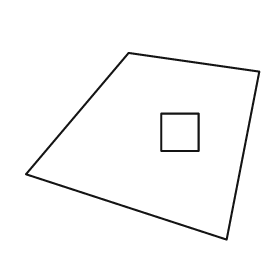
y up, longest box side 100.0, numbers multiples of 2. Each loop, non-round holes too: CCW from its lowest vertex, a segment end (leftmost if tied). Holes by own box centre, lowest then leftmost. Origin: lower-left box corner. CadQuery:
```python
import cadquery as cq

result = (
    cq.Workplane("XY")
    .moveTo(86.0, 0.0)
    .lineTo(100.0, 72.0)
    .lineTo(44.0, 80.0)
    .lineTo(0.0, 28.0)
    .close()
    .moveTo(58.0, 38.0)
    .lineTo(74.0, 38.0)
    .lineTo(74.0, 54.0)
    .lineTo(58.0, 54.0)
    .close()
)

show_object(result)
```